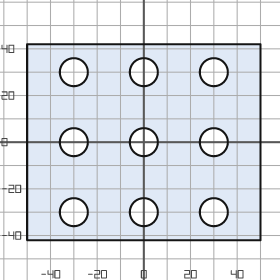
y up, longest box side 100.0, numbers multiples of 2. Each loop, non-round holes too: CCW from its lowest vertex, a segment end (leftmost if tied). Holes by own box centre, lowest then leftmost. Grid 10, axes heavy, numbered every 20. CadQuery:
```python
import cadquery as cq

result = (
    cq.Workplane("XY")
    .moveTo(-50.0, -42.0)
    .lineTo(50.0, -42.0)
    .lineTo(50.0, 42.0)
    .lineTo(-50.0, 42.0)
    .close()
    .moveTo(-30.0, -30.0)
    .circle(6.0)
    .moveTo(0.0, -30.0)
    .circle(6.0)
    .moveTo(30.0, -30.0)
    .circle(6.0)
    .moveTo(-30.0, 0.0)
    .circle(6.0)
    .moveTo(0.0, 0.0)
    .circle(6.0)
    .moveTo(30.0, 0.0)
    .circle(6.0)
    .moveTo(-30.0, 30.0)
    .circle(6.0)
    .moveTo(0.0, 30.0)
    .circle(6.0)
    .moveTo(30.0, 30.0)
    .circle(6.0)
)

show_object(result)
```